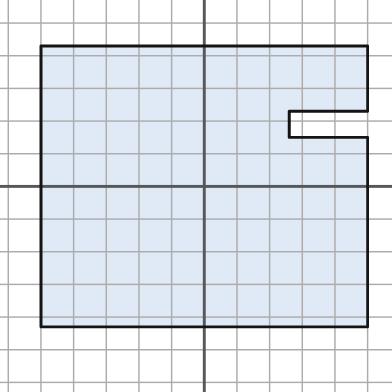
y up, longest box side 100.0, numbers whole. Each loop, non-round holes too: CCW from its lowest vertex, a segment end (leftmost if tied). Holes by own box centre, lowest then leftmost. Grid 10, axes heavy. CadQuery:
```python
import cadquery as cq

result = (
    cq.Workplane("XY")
    .moveTo(-50.0, -43.0)
    .lineTo(50.0, -43.0)
    .lineTo(50.0, 15.0)
    .lineTo(26.0, 15.0)
    .lineTo(26.0, 23.0)
    .lineTo(50.0, 23.0)
    .lineTo(50.0, 43.0)
    .lineTo(-50.0, 43.0)
    .close()
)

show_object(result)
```